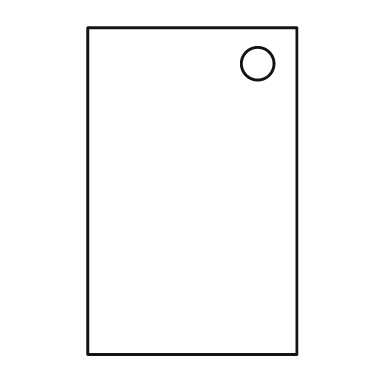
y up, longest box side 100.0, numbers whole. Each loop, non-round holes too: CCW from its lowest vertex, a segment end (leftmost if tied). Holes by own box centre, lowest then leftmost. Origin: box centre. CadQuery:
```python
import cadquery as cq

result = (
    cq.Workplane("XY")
    .moveTo(-32.0, -50.0)
    .lineTo(32.0, -50.0)
    .lineTo(32.0, 50.0)
    .lineTo(-32.0, 50.0)
    .close()
    .moveTo(20.0, 39.0)
    .circle(5.0)
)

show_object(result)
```